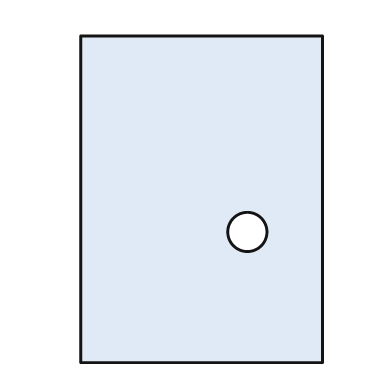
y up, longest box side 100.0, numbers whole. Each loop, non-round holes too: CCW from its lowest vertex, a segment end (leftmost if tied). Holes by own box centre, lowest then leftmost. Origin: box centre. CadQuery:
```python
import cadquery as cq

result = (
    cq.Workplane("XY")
    .moveTo(-37.0, -50.0)
    .lineTo(37.0, -50.0)
    .lineTo(37.0, 50.0)
    .lineTo(-37.0, 50.0)
    .close()
    .moveTo(14.0, -10.0)
    .circle(6.0)
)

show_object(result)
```